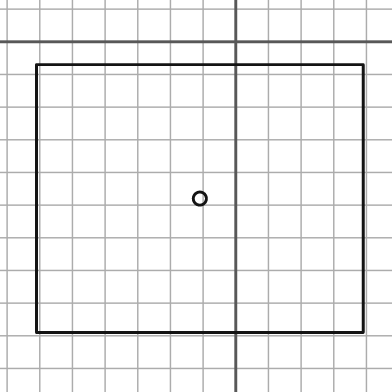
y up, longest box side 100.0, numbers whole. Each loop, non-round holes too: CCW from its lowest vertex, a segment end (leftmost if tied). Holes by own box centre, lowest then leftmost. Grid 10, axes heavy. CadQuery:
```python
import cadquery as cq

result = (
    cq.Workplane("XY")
    .moveTo(-61.0, -89.0)
    .lineTo(39.0, -89.0)
    .lineTo(39.0, -7.0)
    .lineTo(-61.0, -7.0)
    .close()
    .moveTo(-11.0, -48.0)
    .circle(2.0)
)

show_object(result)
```